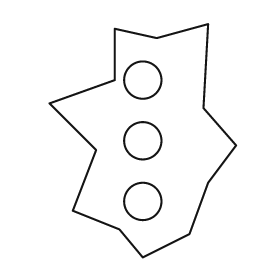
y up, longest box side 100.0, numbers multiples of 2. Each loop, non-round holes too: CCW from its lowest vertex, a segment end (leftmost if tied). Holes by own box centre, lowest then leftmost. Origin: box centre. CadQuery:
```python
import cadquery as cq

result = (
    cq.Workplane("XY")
    .moveTo(0.0, -50.0)
    .lineTo(20.0, -40.0)
    .lineTo(28.0, -18.0)
    .lineTo(40.0, -2.0)
    .lineTo(26.0, 14.0)
    .lineTo(28.0, 50.0)
    .lineTo(6.0, 44.0)
    .lineTo(-12.0, 48.0)
    .lineTo(-12.0, 26.0)
    .lineTo(-40.0, 16.0)
    .lineTo(-20.0, -4.0)
    .lineTo(-30.0, -30.0)
    .lineTo(-10.0, -38.0)
    .close()
    .moveTo(0.0, -26.0)
    .circle(8.0)
    .moveTo(0.0, 0.0)
    .circle(8.0)
    .moveTo(0.0, 26.0)
    .circle(8.0)
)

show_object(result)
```